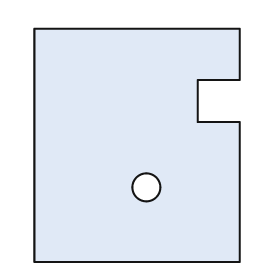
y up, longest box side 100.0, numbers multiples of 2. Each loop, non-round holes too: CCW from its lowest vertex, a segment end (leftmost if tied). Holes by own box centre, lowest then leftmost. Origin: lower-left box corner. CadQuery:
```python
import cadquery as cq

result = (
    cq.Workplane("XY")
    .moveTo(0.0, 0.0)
    .lineTo(88.0, 0.0)
    .lineTo(88.0, 60.0)
    .lineTo(70.0, 60.0)
    .lineTo(70.0, 78.0)
    .lineTo(88.0, 78.0)
    .lineTo(88.0, 100.0)
    .lineTo(0.0, 100.0)
    .close()
    .moveTo(48.0, 32.0)
    .circle(6.0)
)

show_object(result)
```